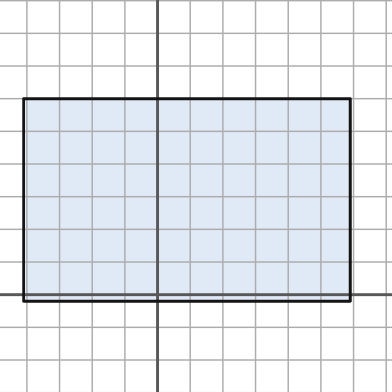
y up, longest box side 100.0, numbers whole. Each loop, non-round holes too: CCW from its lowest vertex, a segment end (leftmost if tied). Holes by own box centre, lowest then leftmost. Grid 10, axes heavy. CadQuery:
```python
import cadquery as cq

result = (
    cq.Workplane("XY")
    .moveTo(-41.0, -2.0)
    .lineTo(59.0, -2.0)
    .lineTo(59.0, 60.0)
    .lineTo(-41.0, 60.0)
    .close()
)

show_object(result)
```